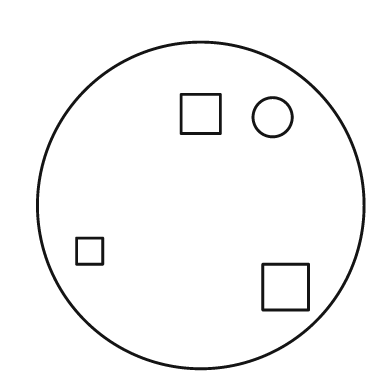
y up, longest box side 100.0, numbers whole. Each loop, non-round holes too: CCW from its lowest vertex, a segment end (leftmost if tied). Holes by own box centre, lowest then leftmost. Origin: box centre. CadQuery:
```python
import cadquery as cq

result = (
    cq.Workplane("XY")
    .moveTo(0.0, 0.0)
    .circle(50.0)
    .moveTo(19.0, -32.0)
    .lineTo(33.0, -32.0)
    .lineTo(33.0, -18.0)
    .lineTo(19.0, -18.0)
    .close()
    .moveTo(-38.0, -18.0)
    .lineTo(-30.0, -18.0)
    .lineTo(-30.0, -10.0)
    .lineTo(-38.0, -10.0)
    .close()
    .moveTo(22.0, 27.0)
    .circle(6.0)
    .moveTo(-6.0, 22.0)
    .lineTo(6.0, 22.0)
    .lineTo(6.0, 34.0)
    .lineTo(-6.0, 34.0)
    .close()
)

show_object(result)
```